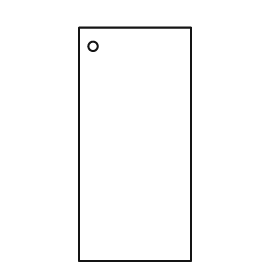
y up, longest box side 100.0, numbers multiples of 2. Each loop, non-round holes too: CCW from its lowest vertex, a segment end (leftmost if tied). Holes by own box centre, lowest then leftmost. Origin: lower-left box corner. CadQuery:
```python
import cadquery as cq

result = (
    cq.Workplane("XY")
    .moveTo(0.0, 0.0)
    .lineTo(48.0, 0.0)
    .lineTo(48.0, 100.0)
    .lineTo(0.0, 100.0)
    .close()
    .moveTo(6.0, 92.0)
    .circle(2.0)
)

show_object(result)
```